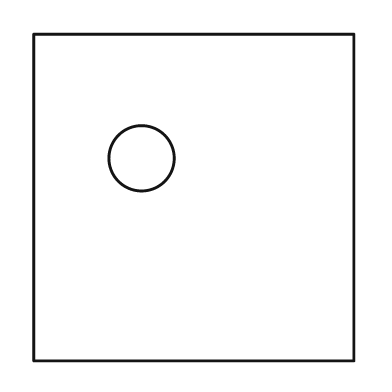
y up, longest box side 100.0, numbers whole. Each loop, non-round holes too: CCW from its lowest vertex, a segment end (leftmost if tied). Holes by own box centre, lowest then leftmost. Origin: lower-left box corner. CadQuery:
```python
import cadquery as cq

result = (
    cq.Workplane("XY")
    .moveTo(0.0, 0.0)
    .lineTo(98.0, 0.0)
    .lineTo(98.0, 100.0)
    .lineTo(0.0, 100.0)
    .close()
    .moveTo(33.0, 62.0)
    .circle(10.0)
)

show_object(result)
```